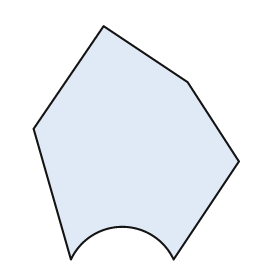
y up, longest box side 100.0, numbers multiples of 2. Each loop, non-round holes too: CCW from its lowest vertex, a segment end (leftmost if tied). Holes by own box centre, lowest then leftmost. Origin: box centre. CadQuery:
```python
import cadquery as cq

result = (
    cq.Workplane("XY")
    .moveTo(-28.0, -50.0)
    .threePointArc((-6.0, -36.0), (16.0, -50.0))
    .lineTo(44.0, -8.0)
    .lineTo(22.0, 26.0)
    .lineTo(-14.0, 50.0)
    .lineTo(-44.0, 6.0)
    .close()
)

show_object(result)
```